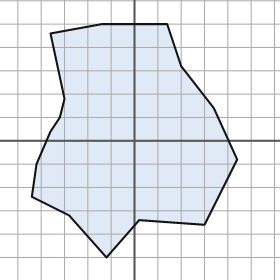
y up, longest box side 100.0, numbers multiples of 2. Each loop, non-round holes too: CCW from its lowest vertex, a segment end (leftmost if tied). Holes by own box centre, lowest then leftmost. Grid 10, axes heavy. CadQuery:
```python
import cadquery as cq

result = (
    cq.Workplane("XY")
    .moveTo(-12.0, -50.0)
    .lineTo(2.0, -34.0)
    .lineTo(30.0, -36.0)
    .lineTo(44.0, -8.0)
    .lineTo(34.0, 14.0)
    .lineTo(20.0, 32.0)
    .lineTo(14.0, 50.0)
    .lineTo(-14.0, 50.0)
    .lineTo(-36.0, 46.0)
    .lineTo(-30.0, 18.0)
    .lineTo(-32.0, 10.0)
    .lineTo(-36.0, 4.0)
    .lineTo(-42.0, -10.0)
    .lineTo(-44.0, -24.0)
    .lineTo(-28.0, -32.0)
    .close()
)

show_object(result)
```